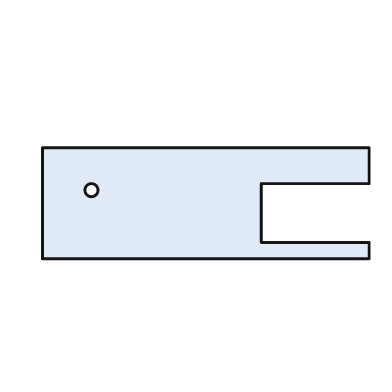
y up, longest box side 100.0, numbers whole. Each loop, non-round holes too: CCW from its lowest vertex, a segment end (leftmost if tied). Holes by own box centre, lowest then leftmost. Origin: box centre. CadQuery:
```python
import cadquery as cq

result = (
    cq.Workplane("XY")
    .moveTo(-50.0, -17.0)
    .lineTo(50.0, -17.0)
    .lineTo(50.0, -12.0)
    .lineTo(17.0, -12.0)
    .lineTo(17.0, 6.0)
    .lineTo(50.0, 6.0)
    .lineTo(50.0, 17.0)
    .lineTo(-50.0, 17.0)
    .close()
    .moveTo(-35.0, 4.0)
    .circle(2.0)
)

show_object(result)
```